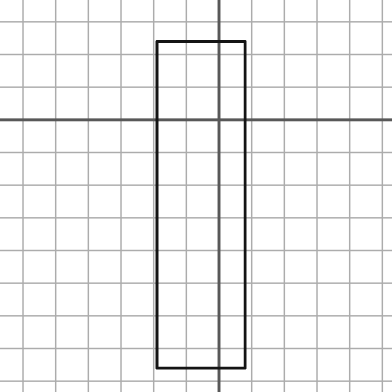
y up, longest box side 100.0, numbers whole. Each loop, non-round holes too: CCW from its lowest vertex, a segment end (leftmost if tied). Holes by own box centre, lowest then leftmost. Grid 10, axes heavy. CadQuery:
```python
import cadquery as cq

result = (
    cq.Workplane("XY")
    .moveTo(-19.0, -76.0)
    .lineTo(8.0, -76.0)
    .lineTo(8.0, 24.0)
    .lineTo(-19.0, 24.0)
    .close()
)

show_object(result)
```